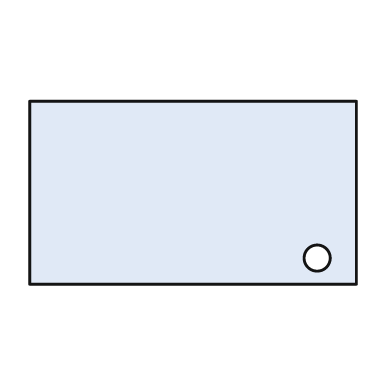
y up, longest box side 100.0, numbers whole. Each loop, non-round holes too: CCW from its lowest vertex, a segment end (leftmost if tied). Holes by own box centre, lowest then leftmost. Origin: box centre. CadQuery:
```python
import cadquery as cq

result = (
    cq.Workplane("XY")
    .moveTo(-50.0, -28.0)
    .lineTo(50.0, -28.0)
    .lineTo(50.0, 28.0)
    .lineTo(-50.0, 28.0)
    .close()
    .moveTo(38.0, -20.0)
    .circle(4.0)
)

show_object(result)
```